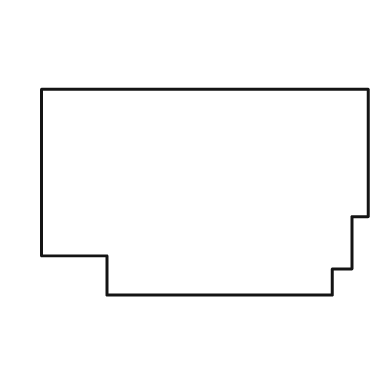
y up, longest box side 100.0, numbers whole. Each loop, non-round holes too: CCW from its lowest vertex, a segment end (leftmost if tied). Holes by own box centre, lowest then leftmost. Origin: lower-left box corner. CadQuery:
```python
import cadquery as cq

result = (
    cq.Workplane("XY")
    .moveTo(20.0, 0.0)
    .lineTo(89.0, 0.0)
    .lineTo(89.0, 8.0)
    .lineTo(95.0, 8.0)
    .lineTo(95.0, 24.0)
    .lineTo(100.0, 24.0)
    .lineTo(100.0, 63.0)
    .lineTo(0.0, 63.0)
    .lineTo(0.0, 12.0)
    .lineTo(20.0, 12.0)
    .close()
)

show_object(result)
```